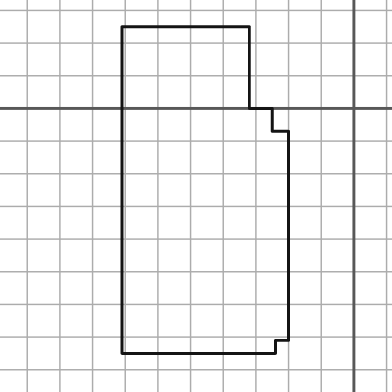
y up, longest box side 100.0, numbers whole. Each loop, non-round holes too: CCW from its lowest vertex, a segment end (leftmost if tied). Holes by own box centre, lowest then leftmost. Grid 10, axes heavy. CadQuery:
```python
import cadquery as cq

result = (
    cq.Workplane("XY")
    .moveTo(-71.0, -75.0)
    .lineTo(-24.0, -75.0)
    .lineTo(-24.0, -71.0)
    .lineTo(-20.0, -71.0)
    .lineTo(-20.0, -7.0)
    .lineTo(-25.0, -7.0)
    .lineTo(-25.0, 0.0)
    .lineTo(-32.0, 0.0)
    .lineTo(-32.0, 25.0)
    .lineTo(-71.0, 25.0)
    .close()
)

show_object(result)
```